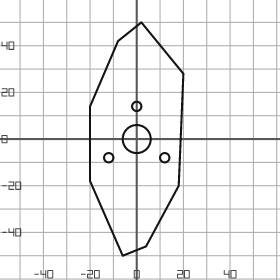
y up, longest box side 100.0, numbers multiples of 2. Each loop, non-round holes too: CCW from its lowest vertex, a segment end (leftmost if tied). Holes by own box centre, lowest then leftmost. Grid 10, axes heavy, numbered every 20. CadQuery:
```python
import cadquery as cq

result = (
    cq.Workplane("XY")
    .moveTo(-6.0, -50.0)
    .lineTo(4.0, -46.0)
    .lineTo(18.0, -20.0)
    .lineTo(20.0, 28.0)
    .lineTo(2.0, 50.0)
    .lineTo(-8.0, 42.0)
    .lineTo(-20.0, 14.0)
    .lineTo(-20.0, -18.0)
    .close()
    .moveTo(-12.0, -8.0)
    .circle(2.0)
    .moveTo(12.0, -8.0)
    .circle(2.0)
    .moveTo(0.0, 0.0)
    .circle(6.0)
    .moveTo(0.0, 14.0)
    .circle(2.0)
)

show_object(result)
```